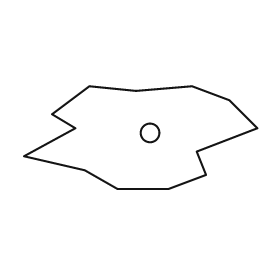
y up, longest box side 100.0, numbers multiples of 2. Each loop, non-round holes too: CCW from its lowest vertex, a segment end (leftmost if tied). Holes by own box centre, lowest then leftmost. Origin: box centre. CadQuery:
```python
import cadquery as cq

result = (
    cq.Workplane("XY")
    .moveTo(-10.0, -22.0)
    .lineTo(12.0, -22.0)
    .lineTo(28.0, -16.0)
    .lineTo(24.0, -6.0)
    .lineTo(50.0, 4.0)
    .lineTo(38.0, 16.0)
    .lineTo(22.0, 22.0)
    .lineTo(-2.0, 20.0)
    .lineTo(-22.0, 22.0)
    .lineTo(-38.0, 10.0)
    .lineTo(-28.0, 4.0)
    .lineTo(-50.0, -8.0)
    .lineTo(-24.0, -14.0)
    .close()
    .moveTo(4.0, 2.0)
    .circle(4.0)
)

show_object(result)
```